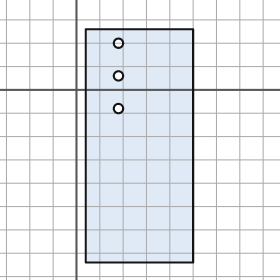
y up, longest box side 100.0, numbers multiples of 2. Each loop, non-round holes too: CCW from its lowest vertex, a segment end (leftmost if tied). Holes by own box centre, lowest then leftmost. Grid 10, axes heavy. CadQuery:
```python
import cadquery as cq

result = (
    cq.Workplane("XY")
    .moveTo(4.0, -74.0)
    .lineTo(50.0, -74.0)
    .lineTo(50.0, 26.0)
    .lineTo(4.0, 26.0)
    .close()
    .moveTo(18.0, -8.0)
    .circle(2.0)
    .moveTo(18.0, 6.0)
    .circle(2.0)
    .moveTo(18.0, 20.0)
    .circle(2.0)
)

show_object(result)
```